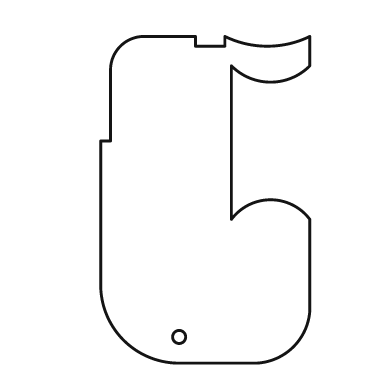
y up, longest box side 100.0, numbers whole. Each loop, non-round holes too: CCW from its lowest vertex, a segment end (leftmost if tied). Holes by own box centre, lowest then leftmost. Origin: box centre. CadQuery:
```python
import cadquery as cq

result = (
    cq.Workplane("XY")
    .moveTo(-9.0, -50.0)
    .lineTo(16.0, -50.0)
    .threePointArc((27.0, -45.0), (32.0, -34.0))
    .lineTo(32.0, -6.0)
    .threePointArc((20.0, 0.0), (8.0, -6.0))
    .lineTo(8.0, 41.0)
    .threePointArc((20.0, 36.0), (32.0, 41.0))
    .lineTo(32.0, 50.0)
    .threePointArc((19.0, 47.0), (6.0, 50.0))
    .lineTo(6.0, 47.0)
    .lineTo(-3.0, 47.0)
    .lineTo(-3.0, 50.0)
    .lineTo(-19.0, 50.0)
    .threePointArc((-26.0, 47.0), (-29.0, 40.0))
    .lineTo(-29.0, 18.0)
    .lineTo(-32.0, 18.0)
    .lineTo(-32.0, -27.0)
    .threePointArc((-25.0, -43.0), (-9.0, -50.0))
    .close()
    .moveTo(-8.0, -42.0)
    .circle(2.0)
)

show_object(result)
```